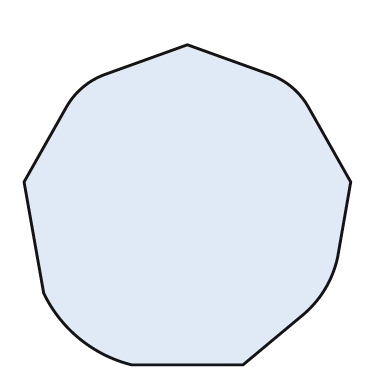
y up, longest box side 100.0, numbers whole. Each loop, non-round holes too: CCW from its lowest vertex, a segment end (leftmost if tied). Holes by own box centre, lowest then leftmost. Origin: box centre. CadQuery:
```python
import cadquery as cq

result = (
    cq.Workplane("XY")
    .moveTo(-17.0, -49.0)
    .lineTo(17.0, -49.0)
    .lineTo(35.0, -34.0)
    .threePointArc((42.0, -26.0), (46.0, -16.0))
    .lineTo(50.0, 7.0)
    .lineTo(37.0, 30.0)
    .threePointArc((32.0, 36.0), (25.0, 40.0))
    .lineTo(0.0, 49.0)
    .lineTo(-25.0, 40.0)
    .threePointArc((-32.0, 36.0), (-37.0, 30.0))
    .lineTo(-50.0, 7.0)
    .lineTo(-44.0, -27.0)
    .threePointArc((-33.0, -41.0), (-17.0, -49.0))
    .close()
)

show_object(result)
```